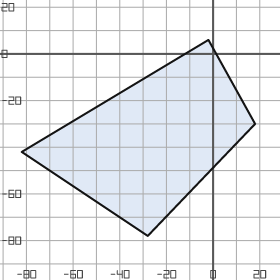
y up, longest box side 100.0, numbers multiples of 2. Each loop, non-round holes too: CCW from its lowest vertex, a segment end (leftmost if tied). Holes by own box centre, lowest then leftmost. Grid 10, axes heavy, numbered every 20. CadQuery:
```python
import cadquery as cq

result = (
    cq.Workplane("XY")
    .moveTo(-28.0, -78.0)
    .lineTo(18.0, -30.0)
    .lineTo(-2.0, 6.0)
    .lineTo(-82.0, -42.0)
    .close()
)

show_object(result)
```